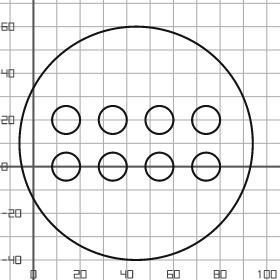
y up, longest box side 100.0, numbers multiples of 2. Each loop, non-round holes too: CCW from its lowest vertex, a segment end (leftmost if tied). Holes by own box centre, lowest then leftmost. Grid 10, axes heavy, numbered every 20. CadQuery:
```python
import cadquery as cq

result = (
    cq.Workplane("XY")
    .moveTo(44.0, 10.0)
    .circle(50.0)
    .moveTo(14.0, 0.0)
    .circle(6.0)
    .moveTo(34.0, 0.0)
    .circle(6.0)
    .moveTo(54.0, 0.0)
    .circle(6.0)
    .moveTo(74.0, 0.0)
    .circle(6.0)
    .moveTo(14.0, 20.0)
    .circle(6.0)
    .moveTo(34.0, 20.0)
    .circle(6.0)
    .moveTo(54.0, 20.0)
    .circle(6.0)
    .moveTo(74.0, 20.0)
    .circle(6.0)
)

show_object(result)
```